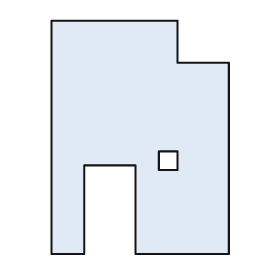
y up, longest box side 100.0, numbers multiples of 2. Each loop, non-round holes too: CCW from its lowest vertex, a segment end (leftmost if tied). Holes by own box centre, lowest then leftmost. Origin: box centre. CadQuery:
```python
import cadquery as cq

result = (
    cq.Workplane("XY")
    .moveTo(-38.0, -50.0)
    .lineTo(-24.0, -50.0)
    .lineTo(-24.0, -12.0)
    .lineTo(-2.0, -12.0)
    .lineTo(-2.0, -50.0)
    .lineTo(38.0, -50.0)
    .lineTo(38.0, 32.0)
    .lineTo(16.0, 32.0)
    .lineTo(16.0, 50.0)
    .lineTo(-38.0, 50.0)
    .close()
    .moveTo(8.0, -14.0)
    .lineTo(16.0, -14.0)
    .lineTo(16.0, -6.0)
    .lineTo(8.0, -6.0)
    .close()
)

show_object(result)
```